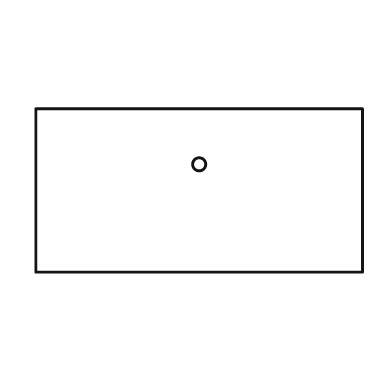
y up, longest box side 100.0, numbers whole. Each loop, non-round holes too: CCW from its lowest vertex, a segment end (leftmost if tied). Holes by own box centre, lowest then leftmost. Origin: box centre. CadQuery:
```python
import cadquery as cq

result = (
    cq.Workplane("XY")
    .moveTo(-50.0, -25.0)
    .lineTo(50.0, -25.0)
    .lineTo(50.0, 25.0)
    .lineTo(-50.0, 25.0)
    .close()
    .moveTo(0.0, 8.0)
    .circle(2.0)
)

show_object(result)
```